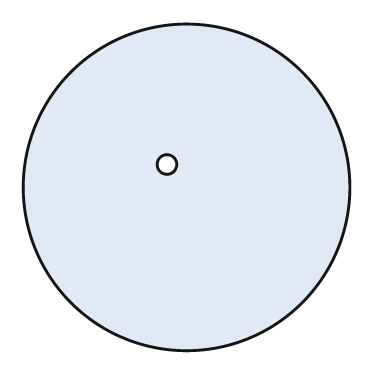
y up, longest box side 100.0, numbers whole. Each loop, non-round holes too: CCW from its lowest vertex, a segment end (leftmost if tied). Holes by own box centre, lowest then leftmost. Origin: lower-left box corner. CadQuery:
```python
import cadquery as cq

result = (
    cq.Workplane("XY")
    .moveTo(50.0, 50.0)
    .circle(50.0)
    .moveTo(44.0, 57.0)
    .circle(3.0)
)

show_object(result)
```